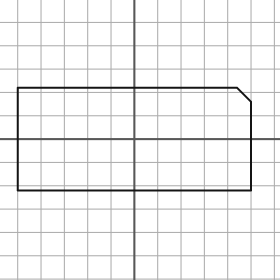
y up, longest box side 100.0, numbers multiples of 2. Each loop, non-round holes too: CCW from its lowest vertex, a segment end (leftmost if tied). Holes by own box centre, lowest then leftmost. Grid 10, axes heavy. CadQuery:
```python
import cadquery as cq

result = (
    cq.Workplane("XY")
    .moveTo(-50.0, -22.0)
    .lineTo(50.0, -22.0)
    .lineTo(50.0, 16.0)
    .lineTo(44.0, 22.0)
    .lineTo(-50.0, 22.0)
    .close()
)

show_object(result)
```